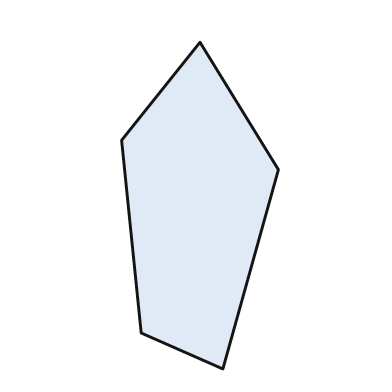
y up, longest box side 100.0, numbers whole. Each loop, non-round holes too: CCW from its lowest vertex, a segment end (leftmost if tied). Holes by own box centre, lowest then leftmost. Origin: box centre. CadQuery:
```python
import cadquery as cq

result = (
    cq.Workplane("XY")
    .moveTo(7.0, -50.0)
    .lineTo(24.0, 11.0)
    .lineTo(0.0, 50.0)
    .lineTo(-24.0, 20.0)
    .lineTo(-18.0, -39.0)
    .close()
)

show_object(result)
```